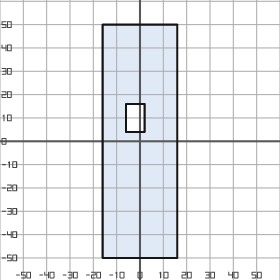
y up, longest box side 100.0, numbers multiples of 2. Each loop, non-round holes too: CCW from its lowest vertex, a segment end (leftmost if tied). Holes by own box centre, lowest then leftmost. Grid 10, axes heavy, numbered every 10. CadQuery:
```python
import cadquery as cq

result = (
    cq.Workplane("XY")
    .moveTo(-16.0, -50.0)
    .lineTo(16.0, -50.0)
    .lineTo(16.0, 50.0)
    .lineTo(-16.0, 50.0)
    .close()
    .moveTo(-6.0, 4.0)
    .lineTo(2.0, 4.0)
    .lineTo(2.0, 16.0)
    .lineTo(-6.0, 16.0)
    .close()
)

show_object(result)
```